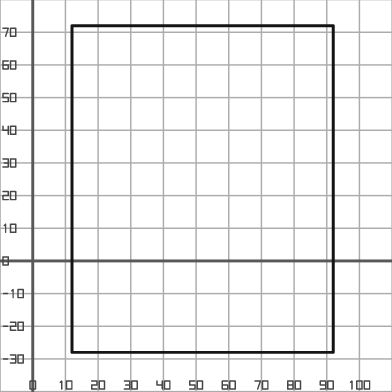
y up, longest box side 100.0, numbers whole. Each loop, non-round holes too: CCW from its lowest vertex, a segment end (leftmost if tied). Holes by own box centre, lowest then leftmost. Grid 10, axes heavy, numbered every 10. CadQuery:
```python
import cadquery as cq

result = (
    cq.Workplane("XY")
    .moveTo(12.0, -28.0)
    .lineTo(92.0, -28.0)
    .lineTo(92.0, 72.0)
    .lineTo(12.0, 72.0)
    .close()
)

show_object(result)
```